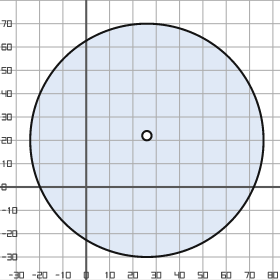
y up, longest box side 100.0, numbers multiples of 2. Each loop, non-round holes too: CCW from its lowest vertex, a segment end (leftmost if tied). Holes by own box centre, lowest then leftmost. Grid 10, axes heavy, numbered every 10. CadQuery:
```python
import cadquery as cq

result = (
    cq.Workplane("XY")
    .moveTo(26.0, 20.0)
    .circle(50.0)
    .moveTo(26.0, 22.0)
    .circle(2.0)
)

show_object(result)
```